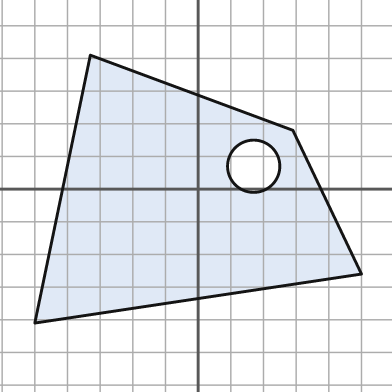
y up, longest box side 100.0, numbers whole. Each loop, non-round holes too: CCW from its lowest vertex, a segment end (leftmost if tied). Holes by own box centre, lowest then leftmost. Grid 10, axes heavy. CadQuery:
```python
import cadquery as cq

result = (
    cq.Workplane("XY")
    .moveTo(-50.0, -41.0)
    .lineTo(50.0, -26.0)
    .lineTo(29.0, 18.0)
    .lineTo(-33.0, 41.0)
    .close()
    .moveTo(17.0, 7.0)
    .circle(8.0)
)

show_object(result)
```